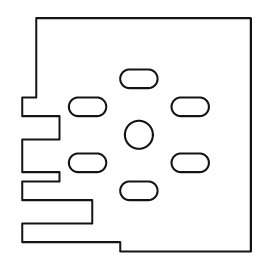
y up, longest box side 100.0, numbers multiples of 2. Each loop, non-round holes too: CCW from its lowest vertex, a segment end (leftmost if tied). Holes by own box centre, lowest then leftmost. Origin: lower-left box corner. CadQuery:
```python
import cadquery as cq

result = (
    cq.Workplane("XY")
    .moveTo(42.0, 0.0)
    .lineTo(98.0, 0.0)
    .lineTo(98.0, 100.0)
    .lineTo(6.0, 100.0)
    .lineTo(6.0, 66.0)
    .lineTo(0.0, 66.0)
    .lineTo(0.0, 58.0)
    .lineTo(16.0, 58.0)
    .lineTo(16.0, 48.0)
    .lineTo(0.0, 48.0)
    .lineTo(0.0, 34.0)
    .lineTo(16.0, 34.0)
    .lineTo(16.0, 30.0)
    .lineTo(0.0, 30.0)
    .lineTo(0.0, 22.0)
    .lineTo(30.0, 22.0)
    .lineTo(30.0, 12.0)
    .lineTo(0.0, 12.0)
    .lineTo(0.0, 4.0)
    .lineTo(42.0, 4.0)
    .close()
    .moveTo(46.0, 22.0)
    .lineTo(54.0, 22.0)
    .threePointArc((58.0, 26.0), (54.0, 30.0))
    .lineTo(46.0, 30.0)
    .threePointArc((42.0, 26.0), (46.0, 22.0))
    .close()
    .moveTo(24.0, 34.0)
    .lineTo(32.0, 34.0)
    .threePointArc((36.0, 38.0), (32.0, 42.0))
    .lineTo(24.0, 42.0)
    .threePointArc((20.0, 38.0), (24.0, 34.0))
    .close()
    .moveTo(68.0, 34.0)
    .lineTo(76.0, 34.0)
    .threePointArc((80.0, 38.0), (76.0, 42.0))
    .lineTo(68.0, 42.0)
    .threePointArc((64.0, 38.0), (68.0, 34.0))
    .close()
    .moveTo(50.0, 50.0)
    .circle(6.0)
    .moveTo(24.0, 58.0)
    .lineTo(32.0, 58.0)
    .threePointArc((36.0, 62.0), (32.0, 66.0))
    .lineTo(24.0, 66.0)
    .threePointArc((20.0, 62.0), (24.0, 58.0))
    .close()
    .moveTo(68.0, 58.0)
    .lineTo(76.0, 58.0)
    .threePointArc((80.0, 62.0), (76.0, 66.0))
    .lineTo(68.0, 66.0)
    .threePointArc((64.0, 62.0), (68.0, 58.0))
    .close()
    .moveTo(46.0, 70.0)
    .lineTo(54.0, 70.0)
    .threePointArc((58.0, 74.0), (54.0, 78.0))
    .lineTo(46.0, 78.0)
    .threePointArc((42.0, 74.0), (46.0, 70.0))
    .close()
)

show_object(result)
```